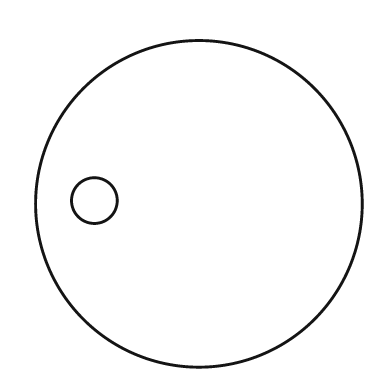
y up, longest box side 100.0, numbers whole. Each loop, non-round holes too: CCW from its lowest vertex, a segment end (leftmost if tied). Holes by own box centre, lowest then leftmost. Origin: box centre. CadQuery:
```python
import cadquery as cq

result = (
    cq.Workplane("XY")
    .moveTo(0.0, 0.0)
    .circle(50.0)
    .moveTo(-32.0, 1.0)
    .circle(7.0)
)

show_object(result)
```